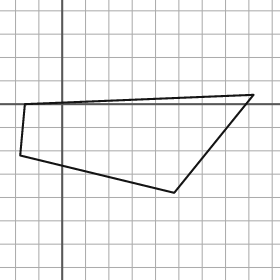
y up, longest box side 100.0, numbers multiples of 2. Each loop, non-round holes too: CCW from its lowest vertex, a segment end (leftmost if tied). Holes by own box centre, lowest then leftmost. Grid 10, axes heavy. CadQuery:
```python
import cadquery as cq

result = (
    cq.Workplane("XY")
    .moveTo(48.0, -38.0)
    .lineTo(82.0, 4.0)
    .lineTo(-16.0, 0.0)
    .lineTo(-18.0, -22.0)
    .close()
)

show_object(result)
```